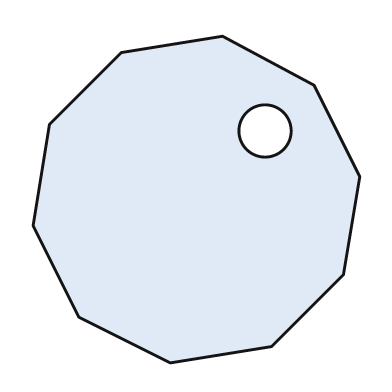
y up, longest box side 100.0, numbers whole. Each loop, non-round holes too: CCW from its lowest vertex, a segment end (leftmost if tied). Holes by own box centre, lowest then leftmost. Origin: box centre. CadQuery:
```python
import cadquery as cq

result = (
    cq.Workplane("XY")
    .moveTo(-8.0, -50.0)
    .lineTo(23.0, -45.0)
    .lineTo(45.0, -23.0)
    .lineTo(50.0, 7.0)
    .lineTo(36.0, 35.0)
    .lineTo(8.0, 50.0)
    .lineTo(-23.0, 45.0)
    .lineTo(-45.0, 23.0)
    .lineTo(-50.0, -8.0)
    .lineTo(-36.0, -36.0)
    .close()
    .moveTo(21.0, 21.0)
    .circle(8.0)
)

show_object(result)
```